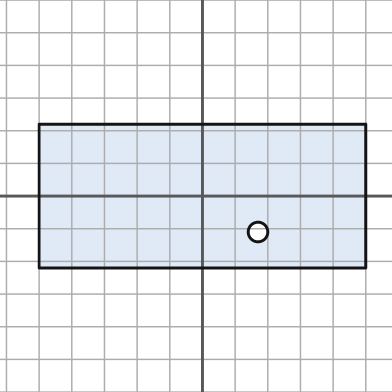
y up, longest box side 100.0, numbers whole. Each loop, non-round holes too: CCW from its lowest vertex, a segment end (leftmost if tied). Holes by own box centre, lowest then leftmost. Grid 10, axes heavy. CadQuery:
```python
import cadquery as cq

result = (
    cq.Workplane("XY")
    .moveTo(-50.0, -22.0)
    .lineTo(50.0, -22.0)
    .lineTo(50.0, 22.0)
    .lineTo(-50.0, 22.0)
    .close()
    .moveTo(17.0, -11.0)
    .circle(3.0)
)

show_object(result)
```